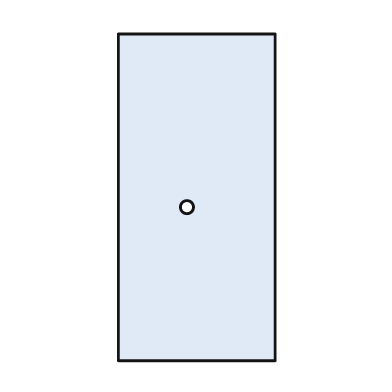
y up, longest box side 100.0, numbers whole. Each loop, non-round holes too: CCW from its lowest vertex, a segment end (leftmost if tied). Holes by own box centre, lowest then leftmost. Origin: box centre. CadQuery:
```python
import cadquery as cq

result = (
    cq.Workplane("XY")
    .moveTo(-24.0, -50.0)
    .lineTo(24.0, -50.0)
    .lineTo(24.0, 50.0)
    .lineTo(-24.0, 50.0)
    .close()
    .moveTo(-3.0, -3.0)
    .circle(2.0)
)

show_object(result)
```